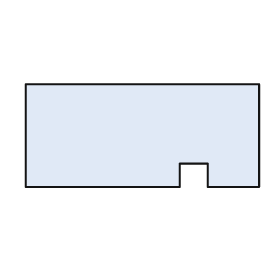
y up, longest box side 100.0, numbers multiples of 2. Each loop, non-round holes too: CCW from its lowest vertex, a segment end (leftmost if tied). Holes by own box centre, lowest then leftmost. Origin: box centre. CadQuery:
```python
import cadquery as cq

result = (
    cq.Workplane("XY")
    .moveTo(-50.0, -22.0)
    .lineTo(16.0, -22.0)
    .lineTo(16.0, -12.0)
    .lineTo(28.0, -12.0)
    .lineTo(28.0, -22.0)
    .lineTo(50.0, -22.0)
    .lineTo(50.0, 22.0)
    .lineTo(-50.0, 22.0)
    .close()
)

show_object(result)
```